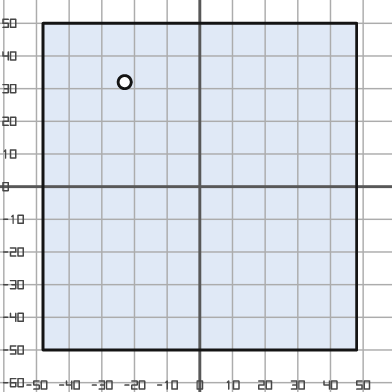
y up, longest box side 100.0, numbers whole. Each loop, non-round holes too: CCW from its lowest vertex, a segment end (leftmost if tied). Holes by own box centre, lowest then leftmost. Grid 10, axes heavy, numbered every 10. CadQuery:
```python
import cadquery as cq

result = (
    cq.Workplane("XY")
    .moveTo(-48.0, -50.0)
    .lineTo(48.0, -50.0)
    .lineTo(48.0, 50.0)
    .lineTo(-48.0, 50.0)
    .close()
    .moveTo(-23.0, 32.0)
    .circle(2.0)
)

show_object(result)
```